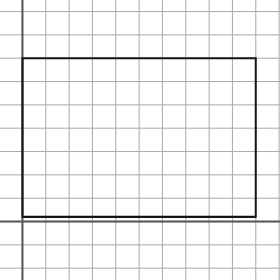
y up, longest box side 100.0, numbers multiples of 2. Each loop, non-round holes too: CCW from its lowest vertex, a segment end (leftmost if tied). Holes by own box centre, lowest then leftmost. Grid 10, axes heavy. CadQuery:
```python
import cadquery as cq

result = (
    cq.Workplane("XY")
    .moveTo(0.0, 2.0)
    .lineTo(100.0, 2.0)
    .lineTo(100.0, 70.0)
    .lineTo(0.0, 70.0)
    .close()
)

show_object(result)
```